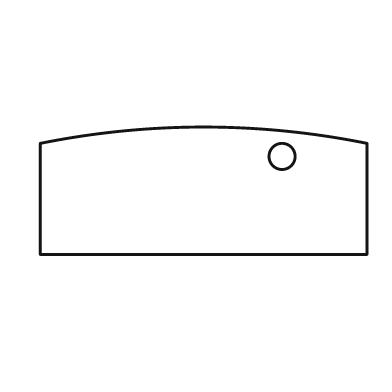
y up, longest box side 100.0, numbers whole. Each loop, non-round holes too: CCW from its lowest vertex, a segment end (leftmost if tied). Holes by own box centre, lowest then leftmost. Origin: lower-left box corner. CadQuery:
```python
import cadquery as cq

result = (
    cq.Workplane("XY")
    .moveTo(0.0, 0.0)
    .lineTo(100.0, 0.0)
    .lineTo(100.0, 34.0)
    .threePointArc((50.0, 39.0), (0.0, 34.0))
    .close()
    .moveTo(74.0, 30.0)
    .circle(4.0)
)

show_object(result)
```